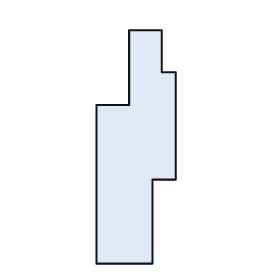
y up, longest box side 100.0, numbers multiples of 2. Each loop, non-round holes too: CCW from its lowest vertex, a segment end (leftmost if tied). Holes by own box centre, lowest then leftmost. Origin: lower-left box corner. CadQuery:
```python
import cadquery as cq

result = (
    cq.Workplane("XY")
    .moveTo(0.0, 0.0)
    .lineTo(24.0, 0.0)
    .lineTo(24.0, 36.0)
    .lineTo(34.0, 36.0)
    .lineTo(34.0, 82.0)
    .lineTo(28.0, 82.0)
    .lineTo(28.0, 100.0)
    .lineTo(14.0, 100.0)
    .lineTo(14.0, 68.0)
    .lineTo(0.0, 68.0)
    .close()
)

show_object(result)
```